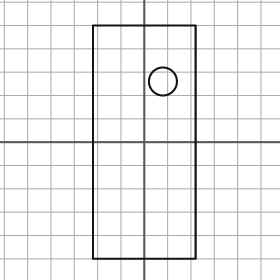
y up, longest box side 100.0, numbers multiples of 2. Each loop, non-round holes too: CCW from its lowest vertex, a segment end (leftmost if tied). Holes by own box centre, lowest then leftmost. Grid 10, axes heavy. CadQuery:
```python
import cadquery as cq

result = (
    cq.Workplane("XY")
    .moveTo(-22.0, -50.0)
    .lineTo(22.0, -50.0)
    .lineTo(22.0, 50.0)
    .lineTo(-22.0, 50.0)
    .close()
    .moveTo(8.0, 26.0)
    .circle(6.0)
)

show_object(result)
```